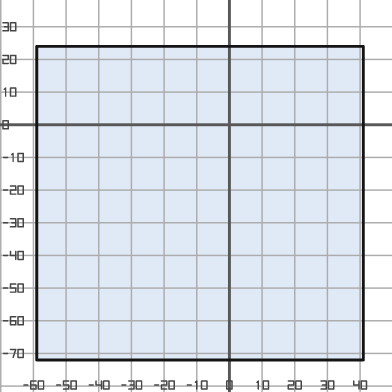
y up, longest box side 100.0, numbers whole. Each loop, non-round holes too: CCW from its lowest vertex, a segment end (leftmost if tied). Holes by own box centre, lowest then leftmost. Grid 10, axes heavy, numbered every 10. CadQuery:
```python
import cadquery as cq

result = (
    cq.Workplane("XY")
    .moveTo(-59.0, -72.0)
    .lineTo(41.0, -72.0)
    .lineTo(41.0, 24.0)
    .lineTo(-59.0, 24.0)
    .close()
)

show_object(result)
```